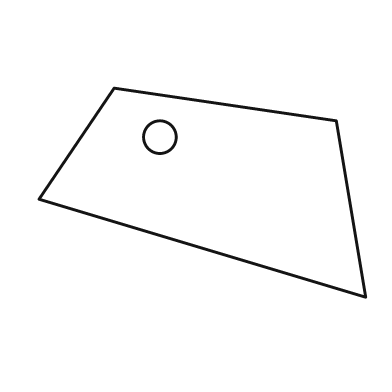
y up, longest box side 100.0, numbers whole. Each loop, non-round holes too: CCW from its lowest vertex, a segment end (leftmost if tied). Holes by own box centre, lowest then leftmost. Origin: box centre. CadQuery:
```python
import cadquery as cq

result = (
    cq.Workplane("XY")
    .moveTo(50.0, -32.0)
    .lineTo(41.0, 22.0)
    .lineTo(-27.0, 32.0)
    .lineTo(-50.0, -2.0)
    .close()
    .moveTo(-13.0, 17.0)
    .circle(5.0)
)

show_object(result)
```